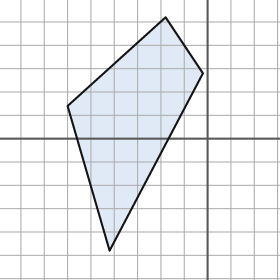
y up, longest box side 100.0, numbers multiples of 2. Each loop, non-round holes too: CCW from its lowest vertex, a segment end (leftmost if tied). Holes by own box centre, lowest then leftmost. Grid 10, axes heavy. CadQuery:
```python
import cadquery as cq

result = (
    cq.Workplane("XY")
    .moveTo(-42.0, -48.0)
    .lineTo(-2.0, 28.0)
    .lineTo(-18.0, 52.0)
    .lineTo(-60.0, 14.0)
    .close()
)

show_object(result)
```